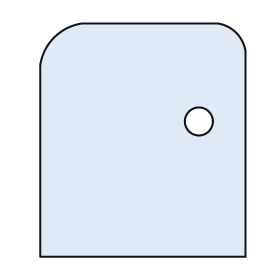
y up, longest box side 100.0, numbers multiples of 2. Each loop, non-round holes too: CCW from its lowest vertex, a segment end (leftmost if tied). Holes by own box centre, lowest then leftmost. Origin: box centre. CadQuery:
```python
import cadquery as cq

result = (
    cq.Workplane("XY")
    .moveTo(-44.0, -50.0)
    .lineTo(44.0, -50.0)
    .lineTo(44.0, 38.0)
    .threePointArc((40.0, 46.0), (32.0, 50.0))
    .lineTo(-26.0, 50.0)
    .threePointArc((-38.0, 44.0), (-44.0, 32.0))
    .close()
    .moveTo(24.0, 8.0)
    .circle(6.0)
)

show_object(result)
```